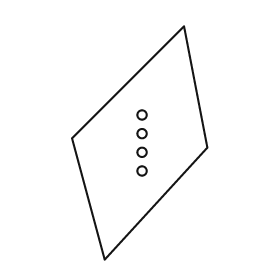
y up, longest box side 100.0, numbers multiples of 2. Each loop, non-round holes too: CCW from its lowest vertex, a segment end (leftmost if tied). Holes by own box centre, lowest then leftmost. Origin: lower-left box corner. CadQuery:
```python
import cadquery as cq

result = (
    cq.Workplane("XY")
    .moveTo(14.0, 0.0)
    .lineTo(58.0, 48.0)
    .lineTo(48.0, 100.0)
    .lineTo(0.0, 52.0)
    .close()
    .moveTo(30.0, 38.0)
    .circle(2.0)
    .moveTo(30.0, 46.0)
    .circle(2.0)
    .moveTo(30.0, 54.0)
    .circle(2.0)
    .moveTo(30.0, 62.0)
    .circle(2.0)
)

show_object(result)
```